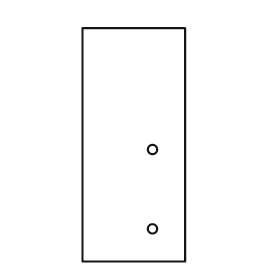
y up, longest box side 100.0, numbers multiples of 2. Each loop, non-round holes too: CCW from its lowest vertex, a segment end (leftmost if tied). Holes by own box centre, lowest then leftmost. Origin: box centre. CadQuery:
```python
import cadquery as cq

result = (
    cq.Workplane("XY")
    .moveTo(-22.0, -50.0)
    .lineTo(22.0, -50.0)
    .lineTo(22.0, 50.0)
    .lineTo(-22.0, 50.0)
    .close()
    .moveTo(8.0, -36.0)
    .circle(2.0)
    .moveTo(8.0, -2.0)
    .circle(2.0)
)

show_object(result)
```